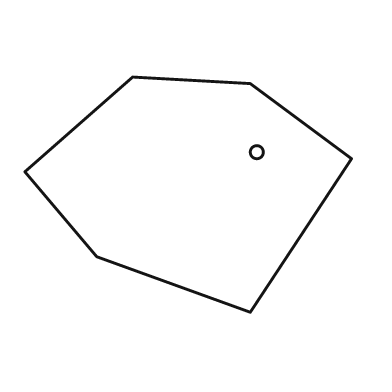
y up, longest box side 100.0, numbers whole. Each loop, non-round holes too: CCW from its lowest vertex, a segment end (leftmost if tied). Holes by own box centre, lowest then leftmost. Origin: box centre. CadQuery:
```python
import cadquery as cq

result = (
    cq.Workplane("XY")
    .moveTo(19.0, -36.0)
    .lineTo(50.0, 11.0)
    .lineTo(19.0, 34.0)
    .lineTo(-17.0, 36.0)
    .lineTo(-50.0, 7.0)
    .lineTo(-28.0, -19.0)
    .close()
    .moveTo(21.0, 13.0)
    .circle(2.0)
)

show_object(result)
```